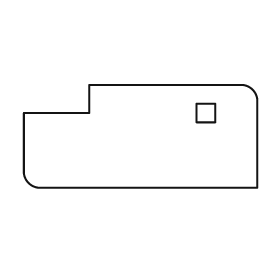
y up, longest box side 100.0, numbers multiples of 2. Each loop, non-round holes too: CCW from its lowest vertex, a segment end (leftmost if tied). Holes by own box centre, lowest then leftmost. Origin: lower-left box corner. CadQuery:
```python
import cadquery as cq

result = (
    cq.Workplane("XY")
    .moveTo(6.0, 0.0)
    .lineTo(100.0, 0.0)
    .lineTo(100.0, 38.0)
    .threePointArc((98.0, 42.0), (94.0, 44.0))
    .lineTo(28.0, 44.0)
    .lineTo(28.0, 32.0)
    .lineTo(0.0, 32.0)
    .lineTo(0.0, 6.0)
    .threePointArc((2.0, 2.0), (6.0, 0.0))
    .close()
    .moveTo(74.0, 28.0)
    .lineTo(82.0, 28.0)
    .lineTo(82.0, 36.0)
    .lineTo(74.0, 36.0)
    .close()
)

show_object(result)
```